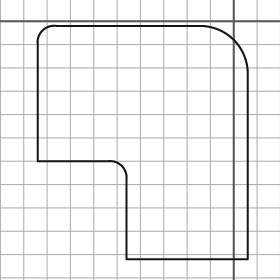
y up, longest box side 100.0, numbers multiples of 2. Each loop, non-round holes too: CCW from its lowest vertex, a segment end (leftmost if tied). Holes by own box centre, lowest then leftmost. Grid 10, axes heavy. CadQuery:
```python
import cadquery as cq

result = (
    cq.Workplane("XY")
    .moveTo(-46.0, -102.0)
    .lineTo(6.0, -102.0)
    .lineTo(6.0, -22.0)
    .threePointArc((0.0, -8.0), (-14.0, -2.0))
    .lineTo(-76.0, -2.0)
    .threePointArc((-82.0, -4.0), (-84.0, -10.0))
    .lineTo(-84.0, -60.0)
    .lineTo(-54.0, -60.0)
    .threePointArc((-48.0, -62.0), (-46.0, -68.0))
    .close()
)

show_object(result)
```